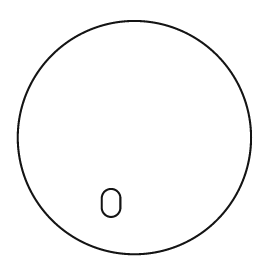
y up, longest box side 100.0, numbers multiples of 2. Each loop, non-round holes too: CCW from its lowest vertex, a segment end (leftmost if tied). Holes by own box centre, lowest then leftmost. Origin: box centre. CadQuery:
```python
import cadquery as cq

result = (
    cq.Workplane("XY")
    .moveTo(0.0, 0.0)
    .circle(50.0)
    .moveTo(-14.0, -30.0)
    .threePointArc((-10.0, -34.0), (-6.0, -30.0))
    .lineTo(-6.0, -26.0)
    .threePointArc((-10.0, -22.0), (-14.0, -26.0))
    .close()
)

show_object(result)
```